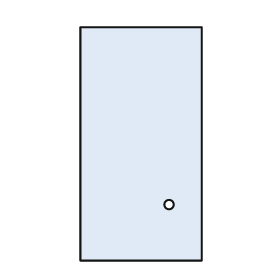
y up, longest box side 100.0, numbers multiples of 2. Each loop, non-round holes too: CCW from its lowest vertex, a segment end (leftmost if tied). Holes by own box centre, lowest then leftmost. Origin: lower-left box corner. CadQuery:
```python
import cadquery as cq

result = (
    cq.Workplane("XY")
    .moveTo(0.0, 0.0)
    .lineTo(52.0, 0.0)
    .lineTo(52.0, 100.0)
    .lineTo(0.0, 100.0)
    .close()
    .moveTo(38.0, 24.0)
    .circle(2.0)
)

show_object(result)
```